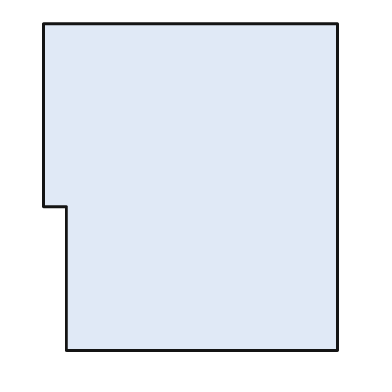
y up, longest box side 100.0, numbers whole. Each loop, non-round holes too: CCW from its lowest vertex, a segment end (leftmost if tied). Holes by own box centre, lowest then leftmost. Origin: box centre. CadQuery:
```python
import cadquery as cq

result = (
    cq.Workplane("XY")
    .moveTo(-38.0, -50.0)
    .lineTo(45.0, -50.0)
    .lineTo(45.0, 50.0)
    .lineTo(-45.0, 50.0)
    .lineTo(-45.0, -6.0)
    .lineTo(-38.0, -6.0)
    .close()
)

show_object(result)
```